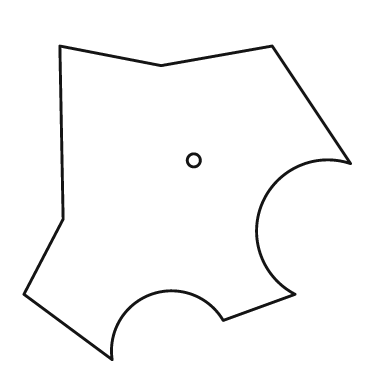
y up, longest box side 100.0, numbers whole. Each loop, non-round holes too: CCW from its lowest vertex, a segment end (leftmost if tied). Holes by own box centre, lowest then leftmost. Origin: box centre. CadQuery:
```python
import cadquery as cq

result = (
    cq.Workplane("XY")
    .moveTo(-23.0, -48.0)
    .threePointArc((-11.0, -28.0), (11.0, -36.0))
    .lineTo(33.0, -28.0)
    .threePointArc((23.0, 0.0), (50.0, 12.0))
    .lineTo(26.0, 48.0)
    .lineTo(-8.0, 42.0)
    .lineTo(-39.0, 48.0)
    .lineTo(-38.0, -5.0)
    .lineTo(-50.0, -28.0)
    .close()
    .moveTo(2.0, 13.0)
    .circle(2.0)
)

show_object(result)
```